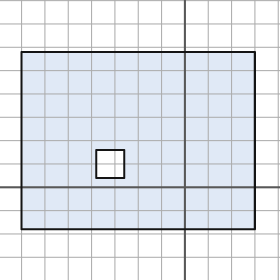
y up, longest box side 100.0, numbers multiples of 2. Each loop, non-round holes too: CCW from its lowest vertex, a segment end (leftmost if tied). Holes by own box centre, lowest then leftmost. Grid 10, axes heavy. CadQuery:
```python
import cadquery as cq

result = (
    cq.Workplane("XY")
    .moveTo(-70.0, -18.0)
    .lineTo(30.0, -18.0)
    .lineTo(30.0, 58.0)
    .lineTo(-70.0, 58.0)
    .close()
    .moveTo(-38.0, 4.0)
    .lineTo(-26.0, 4.0)
    .lineTo(-26.0, 16.0)
    .lineTo(-38.0, 16.0)
    .close()
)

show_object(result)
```